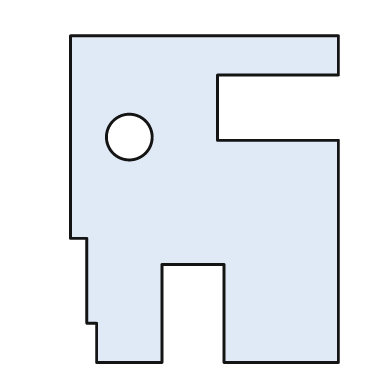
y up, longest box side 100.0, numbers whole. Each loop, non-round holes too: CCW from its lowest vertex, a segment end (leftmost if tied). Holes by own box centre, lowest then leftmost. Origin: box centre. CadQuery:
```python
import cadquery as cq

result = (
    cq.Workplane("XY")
    .moveTo(-33.0, -50.0)
    .lineTo(-13.0, -50.0)
    .lineTo(-13.0, -20.0)
    .lineTo(6.0, -20.0)
    .lineTo(6.0, -50.0)
    .lineTo(41.0, -50.0)
    .lineTo(41.0, 18.0)
    .lineTo(4.0, 18.0)
    .lineTo(4.0, 38.0)
    .lineTo(41.0, 38.0)
    .lineTo(41.0, 50.0)
    .lineTo(-41.0, 50.0)
    .lineTo(-41.0, -12.0)
    .lineTo(-36.0, -12.0)
    .lineTo(-36.0, -38.0)
    .lineTo(-33.0, -38.0)
    .close()
    .moveTo(-23.0, 19.0)
    .circle(7.0)
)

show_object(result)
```